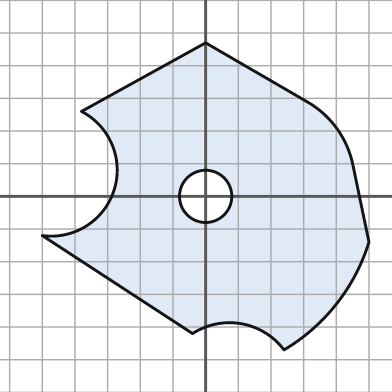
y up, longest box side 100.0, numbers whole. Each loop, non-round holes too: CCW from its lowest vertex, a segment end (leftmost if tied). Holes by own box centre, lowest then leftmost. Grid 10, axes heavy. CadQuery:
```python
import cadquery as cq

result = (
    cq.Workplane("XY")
    .moveTo(24.0, -47.0)
    .threePointArc((40.0, -33.0), (50.0, -14.0))
    .lineTo(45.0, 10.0)
    .threePointArc((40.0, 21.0), (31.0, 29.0))
    .lineTo(0.0, 47.0)
    .lineTo(-38.0, 26.0)
    .threePointArc((-28.0, 2.0), (-50.0, -12.0))
    .lineTo(-4.0, -42.0)
    .threePointArc((11.0, -39.0), (24.0, -47.0))
    .close()
    .moveTo(0.0, 0.0)
    .circle(8.0)
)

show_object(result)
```